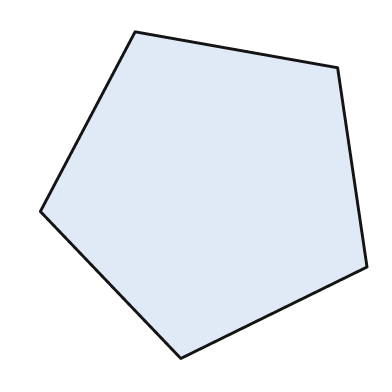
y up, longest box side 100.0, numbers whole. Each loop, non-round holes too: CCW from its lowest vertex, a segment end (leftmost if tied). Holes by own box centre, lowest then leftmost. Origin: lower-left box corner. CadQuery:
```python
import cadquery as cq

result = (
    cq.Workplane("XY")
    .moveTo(43.0, 0.0)
    .lineTo(100.0, 28.0)
    .lineTo(91.0, 89.0)
    .lineTo(29.0, 100.0)
    .lineTo(0.0, 45.0)
    .close()
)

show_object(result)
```